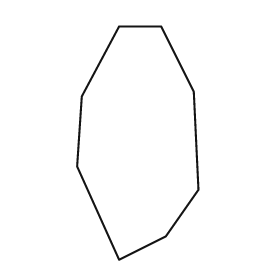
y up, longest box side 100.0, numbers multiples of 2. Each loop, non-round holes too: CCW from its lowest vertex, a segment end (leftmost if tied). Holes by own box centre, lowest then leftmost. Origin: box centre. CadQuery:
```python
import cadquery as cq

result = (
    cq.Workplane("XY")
    .moveTo(-8.0, -50.0)
    .lineTo(12.0, -40.0)
    .lineTo(26.0, -20.0)
    .lineTo(24.0, 22.0)
    .lineTo(10.0, 50.0)
    .lineTo(-8.0, 50.0)
    .lineTo(-24.0, 20.0)
    .lineTo(-26.0, -10.0)
    .close()
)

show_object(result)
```